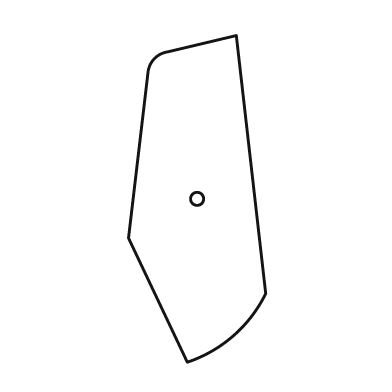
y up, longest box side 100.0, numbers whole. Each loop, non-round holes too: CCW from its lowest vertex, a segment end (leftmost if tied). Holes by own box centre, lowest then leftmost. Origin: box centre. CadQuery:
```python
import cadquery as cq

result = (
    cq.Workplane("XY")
    .moveTo(-3.0, -50.0)
    .threePointArc((11.0, -42.0), (21.0, -29.0))
    .lineTo(12.0, 50.0)
    .lineTo(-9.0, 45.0)
    .threePointArc((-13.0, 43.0), (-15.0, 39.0))
    .lineTo(-21.0, -12.0)
    .close()
    .moveTo(0.0, 0.0)
    .circle(2.0)
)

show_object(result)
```